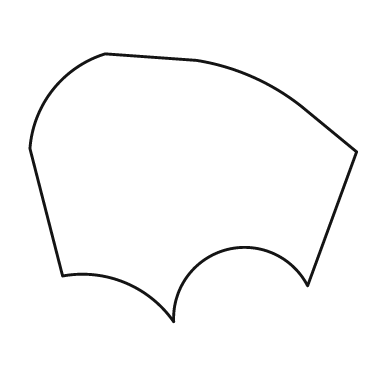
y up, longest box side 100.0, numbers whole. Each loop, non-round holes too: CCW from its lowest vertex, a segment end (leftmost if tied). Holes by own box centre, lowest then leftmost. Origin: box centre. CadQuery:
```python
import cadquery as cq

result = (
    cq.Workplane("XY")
    .moveTo(-6.0, -41.0)
    .threePointArc((10.0, -19.0), (35.0, -30.0))
    .lineTo(50.0, 11.0)
    .lineTo(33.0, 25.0)
    .threePointArc((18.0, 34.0), (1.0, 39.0))
    .lineTo(-27.0, 41.0)
    .threePointArc((-43.0, 30.0), (-50.0, 12.0))
    .lineTo(-40.0, -27.0)
    .threePointArc((-21.0, -29.0), (-6.0, -41.0))
    .close()
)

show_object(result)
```